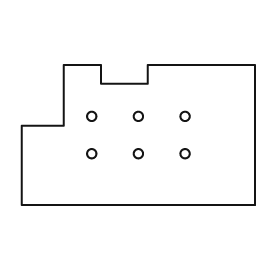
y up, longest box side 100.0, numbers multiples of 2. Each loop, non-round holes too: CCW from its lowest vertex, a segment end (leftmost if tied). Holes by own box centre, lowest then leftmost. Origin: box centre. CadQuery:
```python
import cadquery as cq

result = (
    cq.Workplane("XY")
    .moveTo(-50.0, -30.0)
    .lineTo(50.0, -30.0)
    .lineTo(50.0, 30.0)
    .lineTo(4.0, 30.0)
    .lineTo(4.0, 22.0)
    .lineTo(-16.0, 22.0)
    .lineTo(-16.0, 30.0)
    .lineTo(-32.0, 30.0)
    .lineTo(-32.0, 4.0)
    .lineTo(-50.0, 4.0)
    .close()
    .moveTo(-20.0, -8.0)
    .circle(2.0)
    .moveTo(0.0, -8.0)
    .circle(2.0)
    .moveTo(20.0, -8.0)
    .circle(2.0)
    .moveTo(-20.0, 8.0)
    .circle(2.0)
    .moveTo(0.0, 8.0)
    .circle(2.0)
    .moveTo(20.0, 8.0)
    .circle(2.0)
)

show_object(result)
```